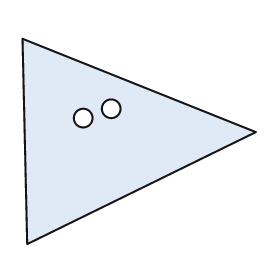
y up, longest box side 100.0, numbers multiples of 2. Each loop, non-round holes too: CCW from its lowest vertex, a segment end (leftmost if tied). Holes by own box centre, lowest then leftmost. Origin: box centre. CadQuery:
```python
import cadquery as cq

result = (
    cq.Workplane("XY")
    .moveTo(-48.0, -44.0)
    .lineTo(50.0, 4.0)
    .lineTo(-50.0, 44.0)
    .close()
    .moveTo(-24.0, 10.0)
    .circle(4.0)
    .moveTo(-12.0, 14.0)
    .circle(4.0)
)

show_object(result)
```